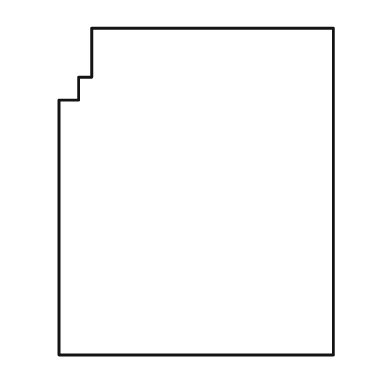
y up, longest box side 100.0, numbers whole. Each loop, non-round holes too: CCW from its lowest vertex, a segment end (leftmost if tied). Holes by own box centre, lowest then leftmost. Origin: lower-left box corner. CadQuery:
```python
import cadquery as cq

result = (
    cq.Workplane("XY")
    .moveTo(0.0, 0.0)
    .lineTo(84.0, 0.0)
    .lineTo(84.0, 100.0)
    .lineTo(10.0, 100.0)
    .lineTo(10.0, 85.0)
    .lineTo(6.0, 85.0)
    .lineTo(6.0, 78.0)
    .lineTo(0.0, 78.0)
    .close()
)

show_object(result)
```